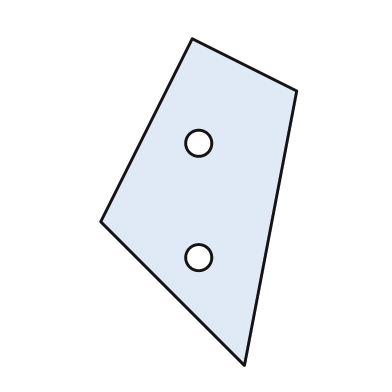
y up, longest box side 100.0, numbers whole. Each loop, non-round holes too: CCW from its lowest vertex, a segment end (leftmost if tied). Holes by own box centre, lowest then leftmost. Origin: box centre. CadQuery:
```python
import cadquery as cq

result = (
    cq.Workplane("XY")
    .moveTo(14.0, -50.0)
    .lineTo(30.0, 34.0)
    .lineTo(-2.0, 50.0)
    .lineTo(-30.0, -6.0)
    .close()
    .moveTo(0.0, -17.0)
    .circle(4.0)
    .moveTo(0.0, 18.0)
    .circle(4.0)
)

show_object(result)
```